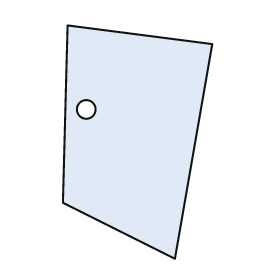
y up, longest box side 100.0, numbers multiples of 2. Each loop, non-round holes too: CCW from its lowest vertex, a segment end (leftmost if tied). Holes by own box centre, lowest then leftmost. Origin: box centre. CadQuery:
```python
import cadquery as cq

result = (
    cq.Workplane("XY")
    .moveTo(16.0, -50.0)
    .lineTo(32.0, 42.0)
    .lineTo(-30.0, 50.0)
    .lineTo(-32.0, -26.0)
    .close()
    .moveTo(-22.0, 14.0)
    .circle(4.0)
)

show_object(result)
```